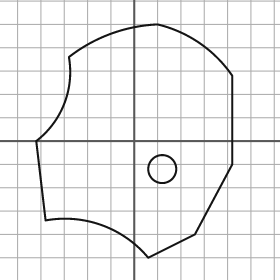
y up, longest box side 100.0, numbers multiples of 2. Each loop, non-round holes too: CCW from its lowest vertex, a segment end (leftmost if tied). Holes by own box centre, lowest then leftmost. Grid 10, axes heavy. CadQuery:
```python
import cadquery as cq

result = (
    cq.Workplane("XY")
    .moveTo(6.0, -50.0)
    .lineTo(26.0, -40.0)
    .lineTo(42.0, -10.0)
    .lineTo(42.0, 28.0)
    .threePointArc((28.0, 42.0), (10.0, 50.0))
    .threePointArc((-10.0, 46.0), (-28.0, 36.0))
    .threePointArc((-30.0, 16.0), (-42.0, 0.0))
    .lineTo(-38.0, -34.0)
    .threePointArc((-14.0, -36.0), (6.0, -50.0))
    .close()
    .moveTo(12.0, -12.0)
    .circle(6.0)
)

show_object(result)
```